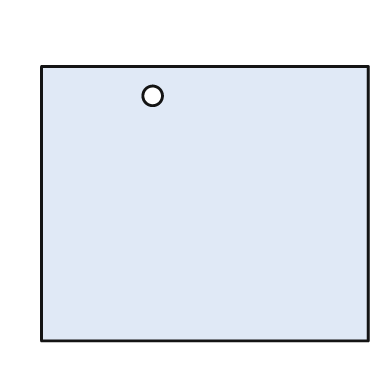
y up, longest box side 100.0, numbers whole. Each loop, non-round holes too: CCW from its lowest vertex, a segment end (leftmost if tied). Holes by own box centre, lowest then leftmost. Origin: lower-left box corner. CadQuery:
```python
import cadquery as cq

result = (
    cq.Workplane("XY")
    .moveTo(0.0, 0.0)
    .lineTo(100.0, 0.0)
    .lineTo(100.0, 84.0)
    .lineTo(0.0, 84.0)
    .close()
    .moveTo(34.0, 75.0)
    .circle(3.0)
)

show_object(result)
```